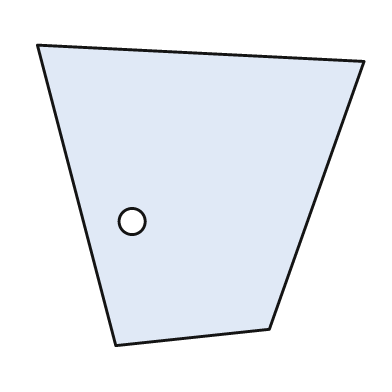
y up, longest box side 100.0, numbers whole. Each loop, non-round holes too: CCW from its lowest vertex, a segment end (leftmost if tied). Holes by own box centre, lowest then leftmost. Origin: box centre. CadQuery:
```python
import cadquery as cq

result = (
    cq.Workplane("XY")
    .moveTo(-26.0, -46.0)
    .lineTo(21.0, -41.0)
    .lineTo(50.0, 41.0)
    .lineTo(-50.0, 46.0)
    .close()
    .moveTo(-21.0, -8.0)
    .circle(4.0)
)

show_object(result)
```